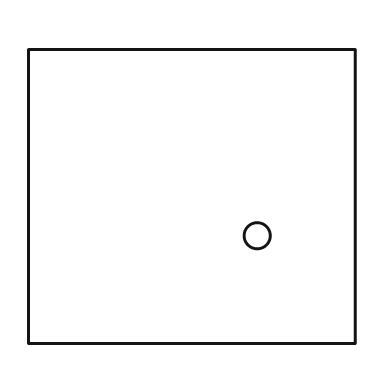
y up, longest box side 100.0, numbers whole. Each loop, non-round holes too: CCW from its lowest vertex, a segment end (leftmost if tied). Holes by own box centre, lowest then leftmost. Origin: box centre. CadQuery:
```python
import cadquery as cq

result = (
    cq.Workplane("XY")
    .moveTo(-50.0, -45.0)
    .lineTo(50.0, -45.0)
    .lineTo(50.0, 45.0)
    .lineTo(-50.0, 45.0)
    .close()
    .moveTo(20.0, -12.0)
    .circle(4.0)
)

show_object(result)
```